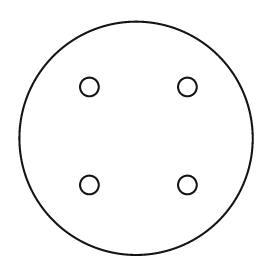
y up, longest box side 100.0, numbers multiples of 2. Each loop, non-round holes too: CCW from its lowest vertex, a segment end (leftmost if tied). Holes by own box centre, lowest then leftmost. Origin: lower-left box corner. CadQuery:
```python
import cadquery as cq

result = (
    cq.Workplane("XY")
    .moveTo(50.0, 50.0)
    .circle(50.0)
    .moveTo(30.0, 30.0)
    .circle(4.0)
    .moveTo(72.0, 30.0)
    .circle(4.0)
    .moveTo(30.0, 72.0)
    .circle(4.0)
    .moveTo(72.0, 72.0)
    .circle(4.0)
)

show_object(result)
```